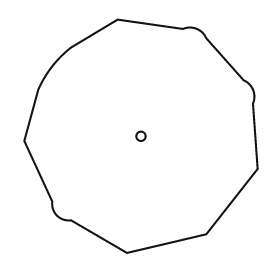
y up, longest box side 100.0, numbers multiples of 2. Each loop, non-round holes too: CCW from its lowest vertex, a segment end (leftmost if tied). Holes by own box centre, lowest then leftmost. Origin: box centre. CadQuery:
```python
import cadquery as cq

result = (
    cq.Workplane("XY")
    .moveTo(-6.0, -50.0)
    .lineTo(28.0, -42.0)
    .lineTo(50.0, -14.0)
    .lineTo(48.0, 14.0)
    .threePointArc((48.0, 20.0), (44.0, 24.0))
    .lineTo(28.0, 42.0)
    .threePointArc((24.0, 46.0), (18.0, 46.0))
    .lineTo(-10.0, 50.0)
    .lineTo(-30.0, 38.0)
    .threePointArc((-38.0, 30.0), (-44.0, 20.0))
    .lineTo(-50.0, -2.0)
    .lineTo(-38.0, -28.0)
    .threePointArc((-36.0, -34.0), (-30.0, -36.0))
    .close()
    .moveTo(0.0, 0.0)
    .circle(2.0)
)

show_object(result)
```